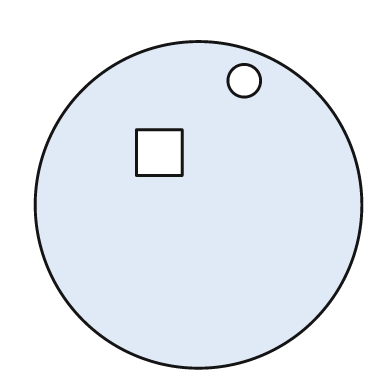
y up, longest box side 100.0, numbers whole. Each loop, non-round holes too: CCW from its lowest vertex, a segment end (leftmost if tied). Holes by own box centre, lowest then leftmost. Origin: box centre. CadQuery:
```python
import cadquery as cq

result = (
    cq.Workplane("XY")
    .moveTo(0.0, 0.0)
    .circle(50.0)
    .moveTo(-19.0, 9.0)
    .lineTo(-5.0, 9.0)
    .lineTo(-5.0, 23.0)
    .lineTo(-19.0, 23.0)
    .close()
    .moveTo(14.0, 38.0)
    .circle(5.0)
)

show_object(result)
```